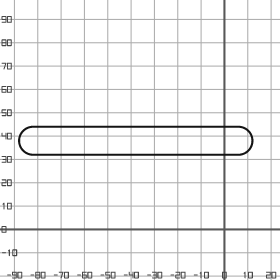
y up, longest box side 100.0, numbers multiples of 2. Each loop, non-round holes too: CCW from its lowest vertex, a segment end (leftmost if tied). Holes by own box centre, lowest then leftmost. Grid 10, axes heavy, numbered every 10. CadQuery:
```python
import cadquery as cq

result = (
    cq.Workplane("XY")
    .moveTo(-82.0, 32.0)
    .lineTo(6.0, 32.0)
    .threePointArc((12.0, 38.0), (6.0, 44.0))
    .lineTo(-82.0, 44.0)
    .threePointArc((-88.0, 38.0), (-82.0, 32.0))
    .close()
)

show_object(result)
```